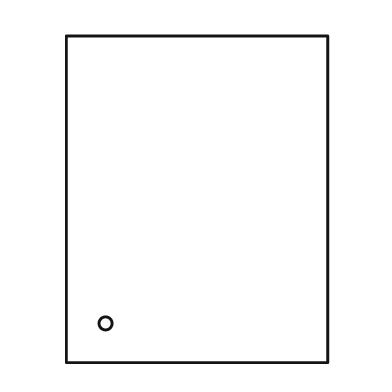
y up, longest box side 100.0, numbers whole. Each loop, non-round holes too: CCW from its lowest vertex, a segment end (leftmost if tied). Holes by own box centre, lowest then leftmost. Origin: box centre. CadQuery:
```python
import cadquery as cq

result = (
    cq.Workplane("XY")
    .moveTo(-40.0, -50.0)
    .lineTo(40.0, -50.0)
    .lineTo(40.0, 50.0)
    .lineTo(-40.0, 50.0)
    .close()
    .moveTo(-28.0, -38.0)
    .circle(2.0)
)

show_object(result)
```